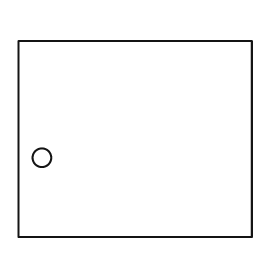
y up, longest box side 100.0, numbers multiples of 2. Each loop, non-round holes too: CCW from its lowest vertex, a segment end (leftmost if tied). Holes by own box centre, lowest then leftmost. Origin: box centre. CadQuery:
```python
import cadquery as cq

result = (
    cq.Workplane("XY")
    .moveTo(-50.0, -42.0)
    .lineTo(50.0, -42.0)
    .lineTo(50.0, 42.0)
    .lineTo(-50.0, 42.0)
    .close()
    .moveTo(-40.0, -8.0)
    .circle(4.0)
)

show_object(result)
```